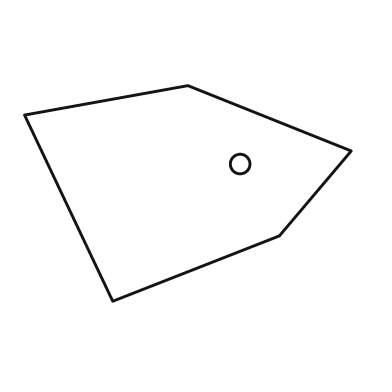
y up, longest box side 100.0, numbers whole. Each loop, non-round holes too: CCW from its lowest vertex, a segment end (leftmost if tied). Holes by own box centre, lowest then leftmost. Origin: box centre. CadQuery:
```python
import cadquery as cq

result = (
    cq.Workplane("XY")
    .moveTo(-23.0, -33.0)
    .lineTo(28.0, -13.0)
    .lineTo(50.0, 13.0)
    .lineTo(0.0, 33.0)
    .lineTo(-50.0, 24.0)
    .close()
    .moveTo(16.0, 9.0)
    .circle(3.0)
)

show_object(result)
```